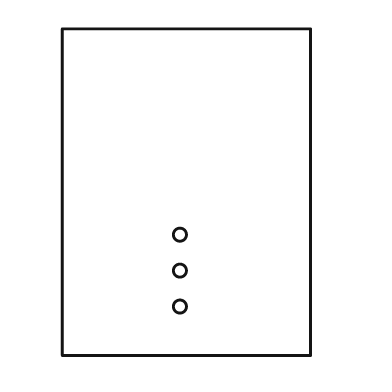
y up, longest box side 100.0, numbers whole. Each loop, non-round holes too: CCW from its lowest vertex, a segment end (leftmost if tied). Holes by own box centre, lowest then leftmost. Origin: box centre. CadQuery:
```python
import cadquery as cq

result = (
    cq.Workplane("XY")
    .moveTo(-38.0, -50.0)
    .lineTo(38.0, -50.0)
    .lineTo(38.0, 50.0)
    .lineTo(-38.0, 50.0)
    .close()
    .moveTo(-2.0, -35.0)
    .circle(2.0)
    .moveTo(-2.0, -24.0)
    .circle(2.0)
    .moveTo(-2.0, -13.0)
    .circle(2.0)
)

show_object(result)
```